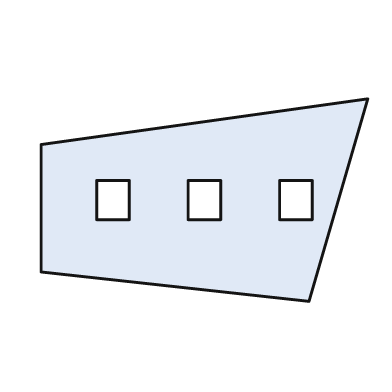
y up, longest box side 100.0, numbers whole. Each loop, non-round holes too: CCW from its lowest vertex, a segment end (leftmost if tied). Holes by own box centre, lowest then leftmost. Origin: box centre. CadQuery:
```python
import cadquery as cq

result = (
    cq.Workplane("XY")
    .moveTo(32.0, -31.0)
    .lineTo(50.0, 31.0)
    .lineTo(-50.0, 17.0)
    .lineTo(-50.0, -22.0)
    .close()
    .moveTo(-33.0, -6.0)
    .lineTo(-23.0, -6.0)
    .lineTo(-23.0, 6.0)
    .lineTo(-33.0, 6.0)
    .close()
    .moveTo(-5.0, -6.0)
    .lineTo(5.0, -6.0)
    .lineTo(5.0, 6.0)
    .lineTo(-5.0, 6.0)
    .close()
    .moveTo(23.0, -6.0)
    .lineTo(33.0, -6.0)
    .lineTo(33.0, 6.0)
    .lineTo(23.0, 6.0)
    .close()
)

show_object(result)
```